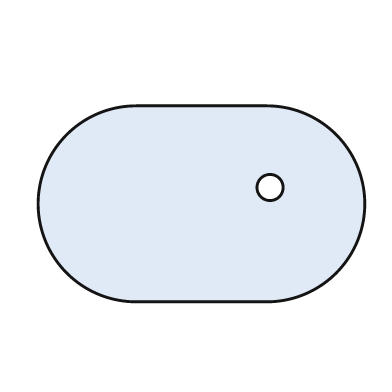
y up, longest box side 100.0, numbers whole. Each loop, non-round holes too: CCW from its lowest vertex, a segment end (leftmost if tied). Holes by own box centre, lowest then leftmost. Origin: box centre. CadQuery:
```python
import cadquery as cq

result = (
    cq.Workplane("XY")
    .moveTo(-20.0, -30.0)
    .lineTo(20.0, -30.0)
    .threePointArc((50.0, 0.0), (20.0, 30.0))
    .lineTo(-20.0, 30.0)
    .threePointArc((-50.0, 0.0), (-20.0, -30.0))
    .close()
    .moveTo(21.0, 5.0)
    .circle(4.0)
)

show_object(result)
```